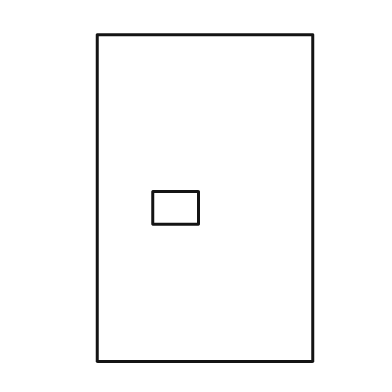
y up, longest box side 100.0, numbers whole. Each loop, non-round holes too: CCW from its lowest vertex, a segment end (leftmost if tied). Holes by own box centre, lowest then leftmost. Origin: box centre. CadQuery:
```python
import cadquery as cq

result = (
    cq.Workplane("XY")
    .moveTo(-33.0, -50.0)
    .lineTo(33.0, -50.0)
    .lineTo(33.0, 50.0)
    .lineTo(-33.0, 50.0)
    .close()
    .moveTo(-16.0, -8.0)
    .lineTo(-2.0, -8.0)
    .lineTo(-2.0, 2.0)
    .lineTo(-16.0, 2.0)
    .close()
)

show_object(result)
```